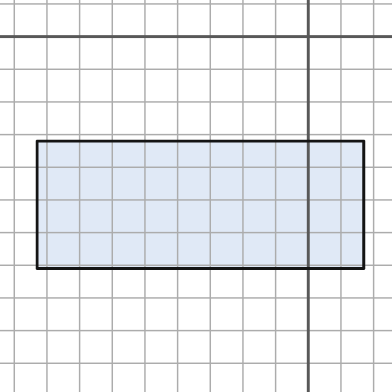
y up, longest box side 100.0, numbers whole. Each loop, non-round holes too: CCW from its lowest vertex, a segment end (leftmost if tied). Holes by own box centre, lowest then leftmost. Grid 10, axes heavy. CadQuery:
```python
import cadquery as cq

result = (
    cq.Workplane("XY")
    .moveTo(-83.0, -71.0)
    .lineTo(17.0, -71.0)
    .lineTo(17.0, -32.0)
    .lineTo(-83.0, -32.0)
    .close()
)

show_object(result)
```